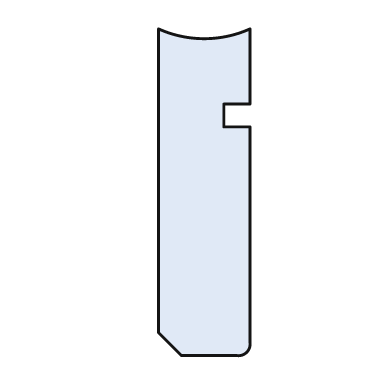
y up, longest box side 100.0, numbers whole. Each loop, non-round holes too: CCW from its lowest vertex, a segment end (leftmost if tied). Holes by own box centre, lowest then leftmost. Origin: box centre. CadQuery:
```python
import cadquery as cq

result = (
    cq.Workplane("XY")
    .moveTo(-7.0, -50.0)
    .lineTo(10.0, -50.0)
    .threePointArc((13.0, -49.0), (14.0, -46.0))
    .lineTo(14.0, 20.0)
    .lineTo(6.0, 20.0)
    .lineTo(6.0, 27.0)
    .lineTo(14.0, 27.0)
    .lineTo(14.0, 50.0)
    .threePointArc((0.0, 47.0), (-14.0, 50.0))
    .lineTo(-14.0, -43.0)
    .close()
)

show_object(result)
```